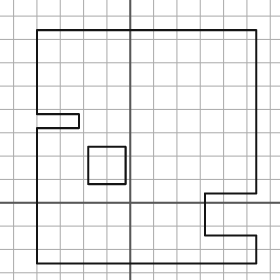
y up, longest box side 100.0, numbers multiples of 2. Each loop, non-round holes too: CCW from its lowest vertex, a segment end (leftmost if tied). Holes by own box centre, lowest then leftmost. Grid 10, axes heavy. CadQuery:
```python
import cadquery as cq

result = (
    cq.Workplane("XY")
    .moveTo(-40.0, -26.0)
    .lineTo(54.0, -26.0)
    .lineTo(54.0, -14.0)
    .lineTo(32.0, -14.0)
    .lineTo(32.0, 4.0)
    .lineTo(54.0, 4.0)
    .lineTo(54.0, 74.0)
    .lineTo(-40.0, 74.0)
    .lineTo(-40.0, 38.0)
    .lineTo(-22.0, 38.0)
    .lineTo(-22.0, 32.0)
    .lineTo(-40.0, 32.0)
    .close()
    .moveTo(-18.0, 8.0)
    .lineTo(-2.0, 8.0)
    .lineTo(-2.0, 24.0)
    .lineTo(-18.0, 24.0)
    .close()
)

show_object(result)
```